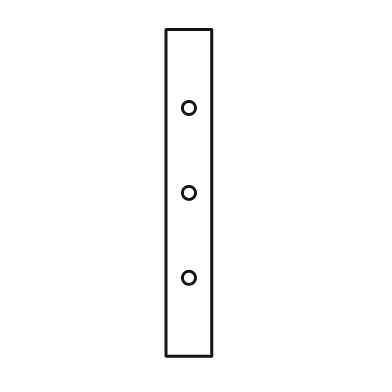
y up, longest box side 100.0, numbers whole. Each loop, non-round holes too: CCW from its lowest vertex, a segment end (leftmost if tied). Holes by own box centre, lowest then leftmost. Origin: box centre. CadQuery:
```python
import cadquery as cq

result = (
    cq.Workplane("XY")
    .moveTo(-7.0, -50.0)
    .lineTo(7.0, -50.0)
    .lineTo(7.0, 50.0)
    .lineTo(-7.0, 50.0)
    .close()
    .moveTo(0.0, -26.0)
    .circle(2.0)
    .moveTo(0.0, 0.0)
    .circle(2.0)
    .moveTo(0.0, 26.0)
    .circle(2.0)
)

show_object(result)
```